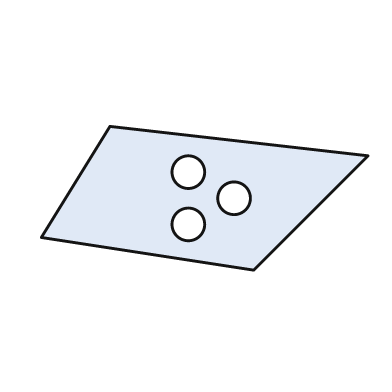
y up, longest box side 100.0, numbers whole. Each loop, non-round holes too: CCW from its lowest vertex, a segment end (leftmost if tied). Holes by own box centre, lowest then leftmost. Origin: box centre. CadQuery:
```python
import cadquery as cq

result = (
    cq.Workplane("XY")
    .moveTo(15.0, -22.0)
    .lineTo(50.0, 13.0)
    .lineTo(-29.0, 22.0)
    .lineTo(-50.0, -12.0)
    .close()
    .moveTo(-5.0, -8.0)
    .circle(5.0)
    .moveTo(9.0, 0.0)
    .circle(5.0)
    .moveTo(-5.0, 8.0)
    .circle(5.0)
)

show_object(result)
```